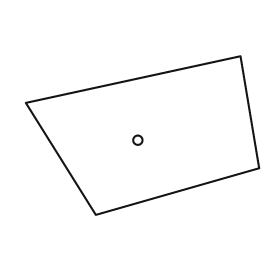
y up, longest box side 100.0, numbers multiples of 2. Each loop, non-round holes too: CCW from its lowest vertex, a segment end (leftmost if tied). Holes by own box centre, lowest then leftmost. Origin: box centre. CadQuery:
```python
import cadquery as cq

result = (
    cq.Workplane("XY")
    .moveTo(-20.0, -34.0)
    .lineTo(50.0, -14.0)
    .lineTo(42.0, 34.0)
    .lineTo(-50.0, 14.0)
    .close()
    .moveTo(-2.0, -2.0)
    .circle(2.0)
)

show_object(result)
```